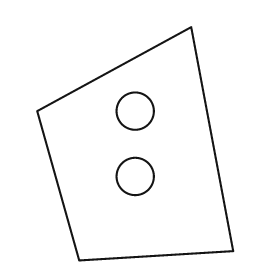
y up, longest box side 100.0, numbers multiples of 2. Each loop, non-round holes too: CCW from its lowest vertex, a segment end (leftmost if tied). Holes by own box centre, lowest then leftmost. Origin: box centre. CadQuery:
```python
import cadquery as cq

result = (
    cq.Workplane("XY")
    .moveTo(-24.0, -50.0)
    .lineTo(42.0, -46.0)
    .lineTo(24.0, 50.0)
    .lineTo(-42.0, 14.0)
    .close()
    .moveTo(0.0, -14.0)
    .circle(8.0)
    .moveTo(0.0, 14.0)
    .circle(8.0)
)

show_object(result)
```